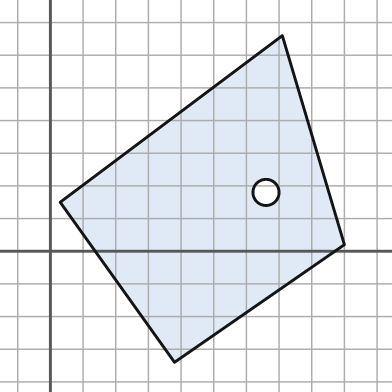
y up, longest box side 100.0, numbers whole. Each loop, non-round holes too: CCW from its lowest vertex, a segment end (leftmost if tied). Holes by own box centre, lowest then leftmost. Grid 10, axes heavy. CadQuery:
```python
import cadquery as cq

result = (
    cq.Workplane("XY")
    .moveTo(38.0, -34.0)
    .lineTo(90.0, 2.0)
    .lineTo(71.0, 66.0)
    .lineTo(3.0, 15.0)
    .close()
    .moveTo(66.0, 18.0)
    .circle(4.0)
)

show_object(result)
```